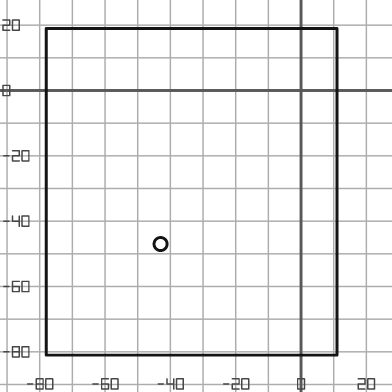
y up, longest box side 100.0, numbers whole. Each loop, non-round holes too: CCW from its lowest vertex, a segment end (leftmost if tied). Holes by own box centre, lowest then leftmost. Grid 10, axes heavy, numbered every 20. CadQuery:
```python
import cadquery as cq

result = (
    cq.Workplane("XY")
    .moveTo(-78.0, -81.0)
    .lineTo(11.0, -81.0)
    .lineTo(11.0, 19.0)
    .lineTo(-78.0, 19.0)
    .close()
    .moveTo(-43.0, -47.0)
    .circle(2.0)
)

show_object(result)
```